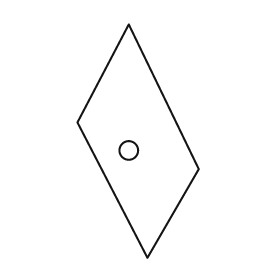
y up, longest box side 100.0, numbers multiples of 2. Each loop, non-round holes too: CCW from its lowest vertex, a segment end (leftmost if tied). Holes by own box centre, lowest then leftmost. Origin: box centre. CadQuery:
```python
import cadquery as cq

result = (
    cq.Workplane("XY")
    .moveTo(4.0, -50.0)
    .lineTo(26.0, -12.0)
    .lineTo(-4.0, 50.0)
    .lineTo(-26.0, 8.0)
    .close()
    .moveTo(-4.0, -4.0)
    .circle(4.0)
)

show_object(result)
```